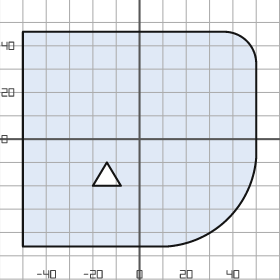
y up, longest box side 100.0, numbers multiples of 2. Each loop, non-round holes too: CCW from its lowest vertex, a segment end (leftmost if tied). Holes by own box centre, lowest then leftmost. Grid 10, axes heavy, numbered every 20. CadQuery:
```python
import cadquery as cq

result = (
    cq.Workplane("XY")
    .moveTo(-50.0, -46.0)
    .lineTo(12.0, -46.0)
    .threePointArc((38.0, -34.0), (50.0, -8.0))
    .lineTo(50.0, 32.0)
    .threePointArc((46.0, 42.0), (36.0, 46.0))
    .lineTo(-50.0, 46.0)
    .close()
    .moveTo(-20.0, -20.0)
    .lineTo(-8.0, -20.0)
    .lineTo(-14.0, -10.0)
    .close()
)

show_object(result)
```